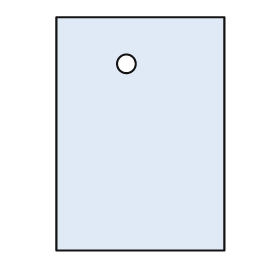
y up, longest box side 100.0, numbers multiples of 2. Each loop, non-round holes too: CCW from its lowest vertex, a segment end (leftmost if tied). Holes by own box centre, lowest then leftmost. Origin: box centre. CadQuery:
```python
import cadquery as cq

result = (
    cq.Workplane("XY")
    .moveTo(-36.0, -50.0)
    .lineTo(36.0, -50.0)
    .lineTo(36.0, 50.0)
    .lineTo(-36.0, 50.0)
    .close()
    .moveTo(-6.0, 30.0)
    .circle(4.0)
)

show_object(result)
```